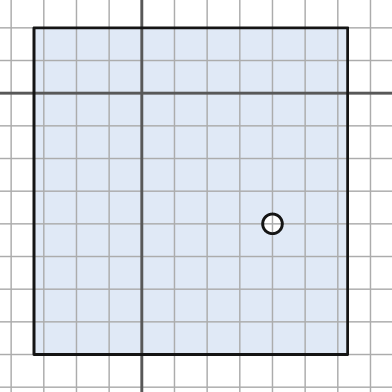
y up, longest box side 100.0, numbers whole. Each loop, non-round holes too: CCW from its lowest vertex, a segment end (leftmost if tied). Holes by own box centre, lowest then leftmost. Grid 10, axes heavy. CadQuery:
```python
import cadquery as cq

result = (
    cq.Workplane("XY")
    .moveTo(-33.0, -80.0)
    .lineTo(63.0, -80.0)
    .lineTo(63.0, 20.0)
    .lineTo(-33.0, 20.0)
    .close()
    .moveTo(40.0, -40.0)
    .circle(3.0)
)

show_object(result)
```